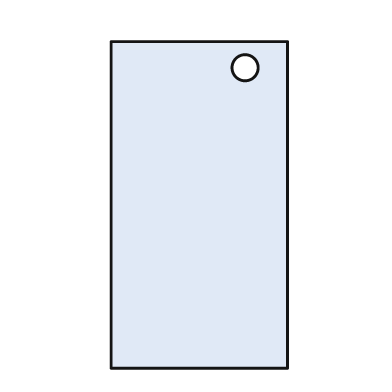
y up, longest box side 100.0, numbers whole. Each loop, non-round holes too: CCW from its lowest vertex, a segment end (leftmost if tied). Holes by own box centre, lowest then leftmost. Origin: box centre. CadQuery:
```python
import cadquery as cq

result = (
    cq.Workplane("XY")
    .moveTo(-27.0, -50.0)
    .lineTo(27.0, -50.0)
    .lineTo(27.0, 50.0)
    .lineTo(-27.0, 50.0)
    .close()
    .moveTo(14.0, 42.0)
    .circle(4.0)
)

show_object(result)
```